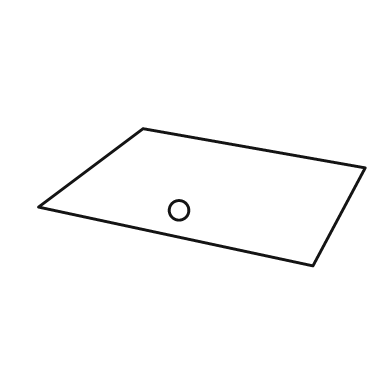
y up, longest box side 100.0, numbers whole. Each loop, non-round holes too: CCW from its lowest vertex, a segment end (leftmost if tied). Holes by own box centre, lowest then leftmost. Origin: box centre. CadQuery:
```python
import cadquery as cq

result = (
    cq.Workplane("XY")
    .moveTo(34.0, -21.0)
    .lineTo(50.0, 9.0)
    .lineTo(-18.0, 21.0)
    .lineTo(-50.0, -3.0)
    .close()
    .moveTo(-7.0, -4.0)
    .circle(3.0)
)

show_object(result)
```